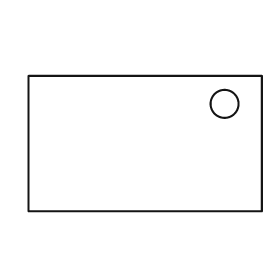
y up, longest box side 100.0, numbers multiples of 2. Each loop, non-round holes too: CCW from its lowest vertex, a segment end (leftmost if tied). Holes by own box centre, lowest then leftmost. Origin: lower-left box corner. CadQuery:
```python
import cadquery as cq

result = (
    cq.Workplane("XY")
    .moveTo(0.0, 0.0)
    .lineTo(100.0, 0.0)
    .lineTo(100.0, 58.0)
    .lineTo(0.0, 58.0)
    .close()
    .moveTo(84.0, 46.0)
    .circle(6.0)
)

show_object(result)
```